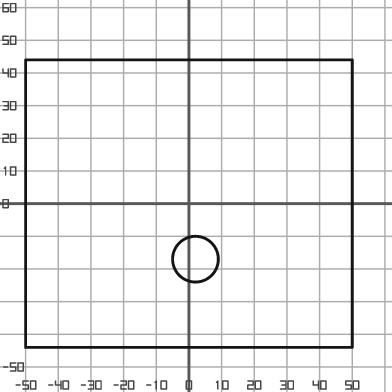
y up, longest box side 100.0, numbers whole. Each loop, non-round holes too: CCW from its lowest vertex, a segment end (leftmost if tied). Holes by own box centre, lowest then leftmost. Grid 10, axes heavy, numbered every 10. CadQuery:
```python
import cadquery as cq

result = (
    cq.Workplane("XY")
    .moveTo(-50.0, -44.0)
    .lineTo(50.0, -44.0)
    .lineTo(50.0, 44.0)
    .lineTo(-50.0, 44.0)
    .close()
    .moveTo(2.0, -17.0)
    .circle(7.0)
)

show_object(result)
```